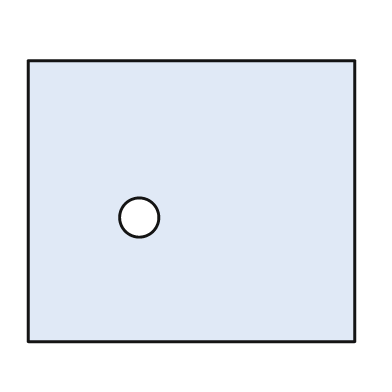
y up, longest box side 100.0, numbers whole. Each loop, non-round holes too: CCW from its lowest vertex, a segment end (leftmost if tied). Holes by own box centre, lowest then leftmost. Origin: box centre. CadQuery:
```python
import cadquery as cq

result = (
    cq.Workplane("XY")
    .moveTo(-50.0, -43.0)
    .lineTo(50.0, -43.0)
    .lineTo(50.0, 43.0)
    .lineTo(-50.0, 43.0)
    .close()
    .moveTo(-16.0, -5.0)
    .circle(6.0)
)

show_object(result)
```